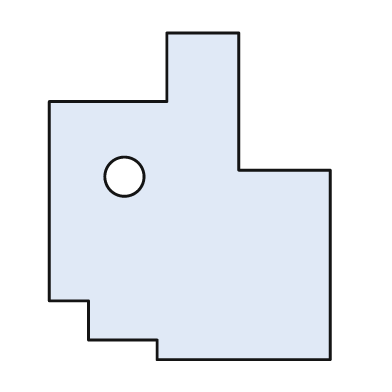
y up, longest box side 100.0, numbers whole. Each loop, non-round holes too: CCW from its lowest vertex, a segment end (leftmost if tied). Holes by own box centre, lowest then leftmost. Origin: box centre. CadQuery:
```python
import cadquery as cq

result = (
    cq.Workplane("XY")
    .moveTo(-10.0, -50.0)
    .lineTo(43.0, -50.0)
    .lineTo(43.0, 8.0)
    .lineTo(15.0, 8.0)
    .lineTo(15.0, 50.0)
    .lineTo(-7.0, 50.0)
    .lineTo(-7.0, 29.0)
    .lineTo(-43.0, 29.0)
    .lineTo(-43.0, -32.0)
    .lineTo(-31.0, -32.0)
    .lineTo(-31.0, -44.0)
    .lineTo(-10.0, -44.0)
    .close()
    .moveTo(-20.0, 6.0)
    .circle(6.0)
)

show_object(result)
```